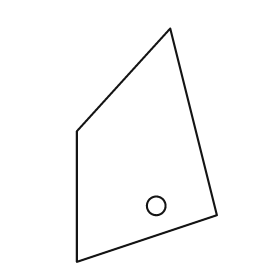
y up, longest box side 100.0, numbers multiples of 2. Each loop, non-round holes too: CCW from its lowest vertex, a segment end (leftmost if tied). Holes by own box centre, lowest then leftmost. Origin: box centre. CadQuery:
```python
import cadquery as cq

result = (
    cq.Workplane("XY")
    .moveTo(-30.0, -50.0)
    .lineTo(30.0, -30.0)
    .lineTo(10.0, 50.0)
    .lineTo(-30.0, 6.0)
    .close()
    .moveTo(4.0, -26.0)
    .circle(4.0)
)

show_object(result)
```